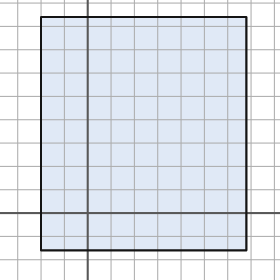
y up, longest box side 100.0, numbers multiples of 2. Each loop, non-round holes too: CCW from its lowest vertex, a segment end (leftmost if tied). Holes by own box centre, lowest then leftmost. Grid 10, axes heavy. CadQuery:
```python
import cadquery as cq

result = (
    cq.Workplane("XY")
    .moveTo(-20.0, -16.0)
    .lineTo(68.0, -16.0)
    .lineTo(68.0, 84.0)
    .lineTo(-20.0, 84.0)
    .close()
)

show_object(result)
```